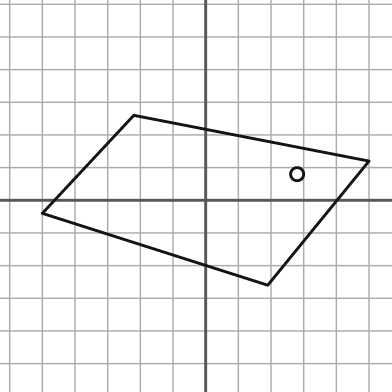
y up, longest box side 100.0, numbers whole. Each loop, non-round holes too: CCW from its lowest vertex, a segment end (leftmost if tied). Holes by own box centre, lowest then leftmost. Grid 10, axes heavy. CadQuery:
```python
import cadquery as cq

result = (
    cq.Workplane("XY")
    .moveTo(19.0, -26.0)
    .lineTo(50.0, 12.0)
    .lineTo(-22.0, 26.0)
    .lineTo(-50.0, -4.0)
    .close()
    .moveTo(28.0, 8.0)
    .circle(2.0)
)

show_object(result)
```